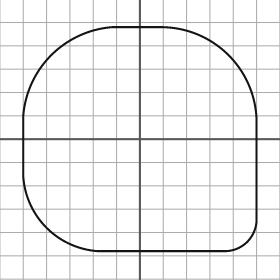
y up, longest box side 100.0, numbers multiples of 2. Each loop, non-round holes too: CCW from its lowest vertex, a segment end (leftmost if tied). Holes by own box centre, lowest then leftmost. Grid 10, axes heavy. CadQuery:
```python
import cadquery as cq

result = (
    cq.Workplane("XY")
    .moveTo(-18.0, -48.0)
    .lineTo(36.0, -48.0)
    .threePointArc((46.0, -44.0), (50.0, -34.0))
    .lineTo(50.0, 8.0)
    .threePointArc((38.0, 36.0), (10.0, 48.0))
    .lineTo(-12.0, 48.0)
    .threePointArc((-38.0, 36.0), (-50.0, 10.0))
    .lineTo(-50.0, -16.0)
    .threePointArc((-40.0, -38.0), (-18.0, -48.0))
    .close()
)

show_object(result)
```